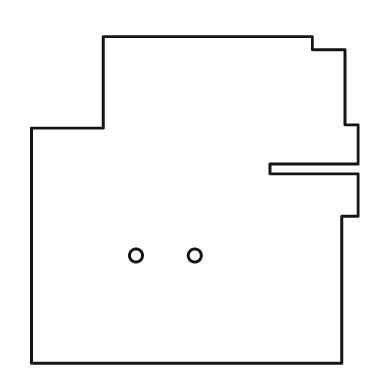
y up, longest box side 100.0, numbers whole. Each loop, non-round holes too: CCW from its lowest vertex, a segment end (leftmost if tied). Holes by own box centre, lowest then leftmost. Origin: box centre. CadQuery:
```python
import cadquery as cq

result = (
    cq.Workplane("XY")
    .moveTo(-50.0, -50.0)
    .lineTo(45.0, -50.0)
    .lineTo(45.0, -5.0)
    .lineTo(50.0, -5.0)
    .lineTo(50.0, 8.0)
    .lineTo(23.0, 8.0)
    .lineTo(23.0, 11.0)
    .lineTo(50.0, 11.0)
    .lineTo(50.0, 23.0)
    .lineTo(46.0, 23.0)
    .lineTo(46.0, 46.0)
    .lineTo(36.0, 46.0)
    .lineTo(36.0, 50.0)
    .lineTo(-28.0, 50.0)
    .lineTo(-28.0, 22.0)
    .lineTo(-50.0, 22.0)
    .close()
    .moveTo(-18.0, -17.0)
    .circle(2.0)
    .moveTo(0.0, -17.0)
    .circle(2.0)
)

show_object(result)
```